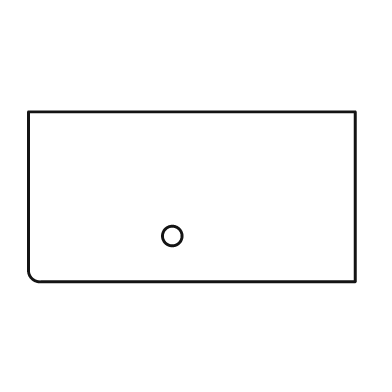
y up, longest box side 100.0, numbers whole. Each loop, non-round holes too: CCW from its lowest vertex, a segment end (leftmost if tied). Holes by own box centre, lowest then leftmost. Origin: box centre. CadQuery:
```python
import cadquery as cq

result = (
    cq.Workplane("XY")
    .moveTo(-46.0, -26.0)
    .lineTo(50.0, -26.0)
    .lineTo(50.0, 26.0)
    .lineTo(-50.0, 26.0)
    .lineTo(-50.0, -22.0)
    .threePointArc((-49.0, -25.0), (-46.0, -26.0))
    .close()
    .moveTo(-6.0, -12.0)
    .circle(3.0)
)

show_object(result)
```